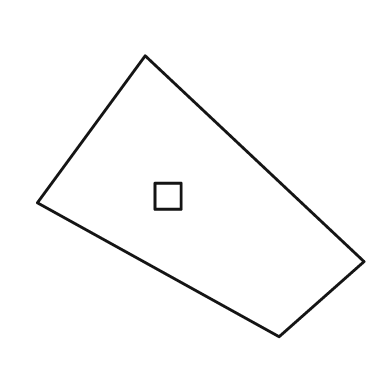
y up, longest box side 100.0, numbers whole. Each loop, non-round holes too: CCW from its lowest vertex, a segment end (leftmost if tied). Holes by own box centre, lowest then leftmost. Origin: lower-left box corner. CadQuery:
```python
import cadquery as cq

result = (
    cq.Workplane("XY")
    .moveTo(74.0, 0.0)
    .lineTo(100.0, 23.0)
    .lineTo(33.0, 86.0)
    .lineTo(0.0, 41.0)
    .close()
    .moveTo(36.0, 39.0)
    .lineTo(44.0, 39.0)
    .lineTo(44.0, 47.0)
    .lineTo(36.0, 47.0)
    .close()
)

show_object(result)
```